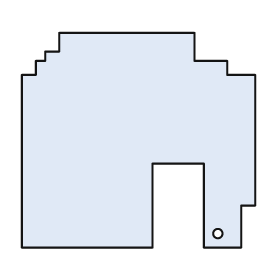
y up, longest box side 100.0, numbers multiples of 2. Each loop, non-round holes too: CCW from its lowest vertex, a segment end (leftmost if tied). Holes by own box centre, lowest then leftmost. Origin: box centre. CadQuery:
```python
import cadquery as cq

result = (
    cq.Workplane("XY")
    .moveTo(-50.0, -46.0)
    .lineTo(6.0, -46.0)
    .lineTo(6.0, -10.0)
    .lineTo(28.0, -10.0)
    .lineTo(28.0, -46.0)
    .lineTo(44.0, -46.0)
    .lineTo(44.0, -28.0)
    .lineTo(50.0, -28.0)
    .lineTo(50.0, 28.0)
    .lineTo(38.0, 28.0)
    .lineTo(38.0, 34.0)
    .lineTo(24.0, 34.0)
    .lineTo(24.0, 46.0)
    .lineTo(-34.0, 46.0)
    .lineTo(-34.0, 38.0)
    .lineTo(-40.0, 38.0)
    .lineTo(-40.0, 34.0)
    .lineTo(-44.0, 34.0)
    .lineTo(-44.0, 28.0)
    .lineTo(-50.0, 28.0)
    .close()
    .moveTo(34.0, -40.0)
    .circle(2.0)
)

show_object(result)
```